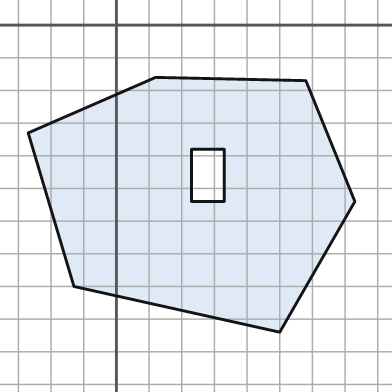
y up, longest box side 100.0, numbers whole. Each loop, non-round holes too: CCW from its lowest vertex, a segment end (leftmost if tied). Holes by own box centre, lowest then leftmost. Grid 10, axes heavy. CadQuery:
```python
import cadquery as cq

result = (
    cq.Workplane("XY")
    .moveTo(50.0, -94.0)
    .lineTo(73.0, -54.0)
    .lineTo(58.0, -17.0)
    .lineTo(12.0, -16.0)
    .lineTo(-27.0, -33.0)
    .lineTo(-13.0, -80.0)
    .close()
    .moveTo(23.0, -54.0)
    .lineTo(33.0, -54.0)
    .lineTo(33.0, -38.0)
    .lineTo(23.0, -38.0)
    .close()
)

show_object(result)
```